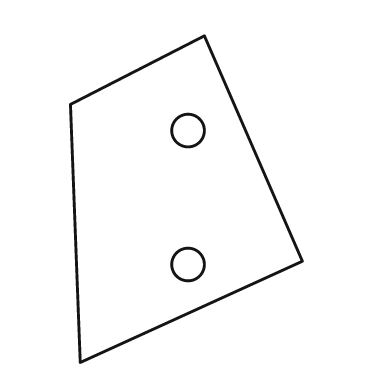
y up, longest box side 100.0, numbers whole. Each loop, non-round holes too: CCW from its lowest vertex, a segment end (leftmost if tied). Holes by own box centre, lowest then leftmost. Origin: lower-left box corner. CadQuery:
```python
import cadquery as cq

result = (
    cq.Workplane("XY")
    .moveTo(3.0, 0.0)
    .lineTo(71.0, 31.0)
    .lineTo(41.0, 100.0)
    .lineTo(0.0, 79.0)
    .close()
    .moveTo(36.0, 30.0)
    .circle(5.0)
    .moveTo(36.0, 71.0)
    .circle(5.0)
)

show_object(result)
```